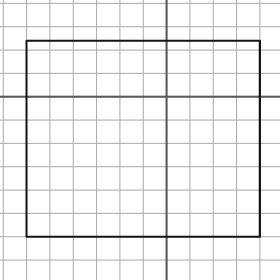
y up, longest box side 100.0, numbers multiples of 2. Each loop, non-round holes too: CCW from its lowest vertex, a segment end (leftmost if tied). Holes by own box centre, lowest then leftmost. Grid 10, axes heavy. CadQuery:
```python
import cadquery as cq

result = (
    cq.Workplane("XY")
    .moveTo(-60.0, -60.0)
    .lineTo(40.0, -60.0)
    .lineTo(40.0, 24.0)
    .lineTo(-60.0, 24.0)
    .close()
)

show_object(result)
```